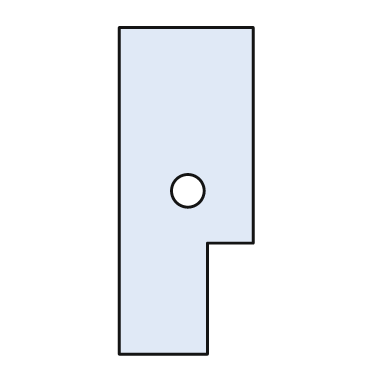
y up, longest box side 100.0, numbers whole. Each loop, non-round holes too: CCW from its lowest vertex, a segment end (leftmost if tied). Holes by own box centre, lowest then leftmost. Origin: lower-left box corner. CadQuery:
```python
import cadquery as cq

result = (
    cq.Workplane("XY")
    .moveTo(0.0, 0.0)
    .lineTo(27.0, 0.0)
    .lineTo(27.0, 34.0)
    .lineTo(41.0, 34.0)
    .lineTo(41.0, 100.0)
    .lineTo(0.0, 100.0)
    .close()
    .moveTo(21.0, 50.0)
    .circle(5.0)
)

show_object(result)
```